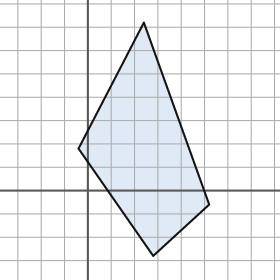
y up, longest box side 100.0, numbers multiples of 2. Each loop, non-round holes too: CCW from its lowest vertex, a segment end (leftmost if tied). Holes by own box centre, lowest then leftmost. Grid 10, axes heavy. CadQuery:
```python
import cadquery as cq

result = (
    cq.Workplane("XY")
    .moveTo(28.0, -28.0)
    .lineTo(52.0, -6.0)
    .lineTo(24.0, 72.0)
    .lineTo(-4.0, 18.0)
    .close()
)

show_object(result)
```